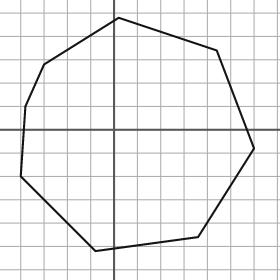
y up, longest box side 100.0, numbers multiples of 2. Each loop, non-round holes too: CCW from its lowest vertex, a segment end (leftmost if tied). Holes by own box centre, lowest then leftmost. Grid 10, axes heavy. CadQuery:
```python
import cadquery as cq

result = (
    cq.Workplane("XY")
    .moveTo(-8.0, -52.0)
    .lineTo(36.0, -46.0)
    .lineTo(60.0, -8.0)
    .lineTo(44.0, 34.0)
    .lineTo(2.0, 48.0)
    .lineTo(-30.0, 28.0)
    .lineTo(-38.0, 10.0)
    .lineTo(-40.0, -20.0)
    .close()
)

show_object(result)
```